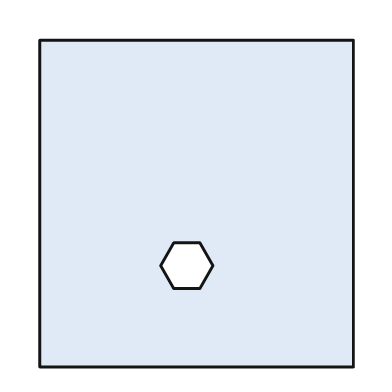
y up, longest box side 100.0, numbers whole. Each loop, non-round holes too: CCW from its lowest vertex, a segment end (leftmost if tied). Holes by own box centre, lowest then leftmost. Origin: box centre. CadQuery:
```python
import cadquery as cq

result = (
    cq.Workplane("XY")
    .moveTo(-48.0, -50.0)
    .lineTo(48.0, -50.0)
    .lineTo(48.0, 50.0)
    .lineTo(-48.0, 50.0)
    .close()
    .moveTo(-7.0, -26.0)
    .lineTo(1.0, -26.0)
    .lineTo(5.0, -19.0)
    .lineTo(1.0, -12.0)
    .lineTo(-7.0, -12.0)
    .lineTo(-11.0, -19.0)
    .close()
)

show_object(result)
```